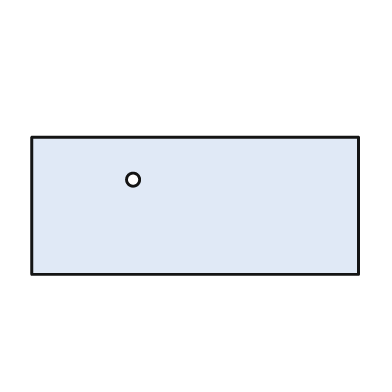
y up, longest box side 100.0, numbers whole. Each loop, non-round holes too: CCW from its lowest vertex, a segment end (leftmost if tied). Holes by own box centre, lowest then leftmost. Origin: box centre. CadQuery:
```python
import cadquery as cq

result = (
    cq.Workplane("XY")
    .moveTo(-50.0, -21.0)
    .lineTo(50.0, -21.0)
    .lineTo(50.0, 21.0)
    .lineTo(-50.0, 21.0)
    .close()
    .moveTo(-19.0, 8.0)
    .circle(2.0)
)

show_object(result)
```